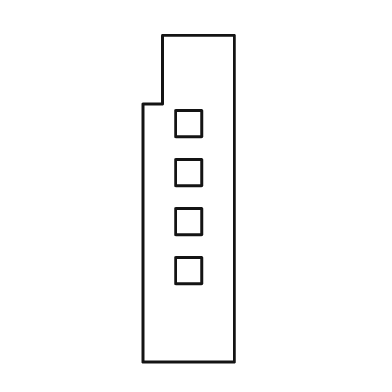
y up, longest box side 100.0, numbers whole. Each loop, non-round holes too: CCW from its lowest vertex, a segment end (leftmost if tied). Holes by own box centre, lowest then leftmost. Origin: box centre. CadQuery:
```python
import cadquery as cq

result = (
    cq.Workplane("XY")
    .moveTo(-14.0, -50.0)
    .lineTo(14.0, -50.0)
    .lineTo(14.0, 50.0)
    .lineTo(-8.0, 50.0)
    .lineTo(-8.0, 29.0)
    .lineTo(-14.0, 29.0)
    .close()
    .moveTo(-4.0, -26.0)
    .lineTo(4.0, -26.0)
    .lineTo(4.0, -18.0)
    .lineTo(-4.0, -18.0)
    .close()
    .moveTo(-4.0, -11.0)
    .lineTo(4.0, -11.0)
    .lineTo(4.0, -3.0)
    .lineTo(-4.0, -3.0)
    .close()
    .moveTo(-4.0, 4.0)
    .lineTo(4.0, 4.0)
    .lineTo(4.0, 12.0)
    .lineTo(-4.0, 12.0)
    .close()
    .moveTo(-4.0, 19.0)
    .lineTo(4.0, 19.0)
    .lineTo(4.0, 27.0)
    .lineTo(-4.0, 27.0)
    .close()
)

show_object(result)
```